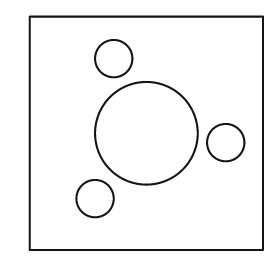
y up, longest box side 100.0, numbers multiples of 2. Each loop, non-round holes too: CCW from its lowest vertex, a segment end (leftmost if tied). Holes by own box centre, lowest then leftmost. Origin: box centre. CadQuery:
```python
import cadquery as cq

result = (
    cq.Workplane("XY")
    .moveTo(-50.0, -50.0)
    .lineTo(50.0, -50.0)
    .lineTo(50.0, 50.0)
    .lineTo(-50.0, 50.0)
    .close()
    .moveTo(-22.0, -28.0)
    .circle(8.0)
    .moveTo(34.0, -4.0)
    .circle(8.0)
    .moveTo(0.0, 0.0)
    .circle(22.0)
    .moveTo(-14.0, 32.0)
    .circle(8.0)
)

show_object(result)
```